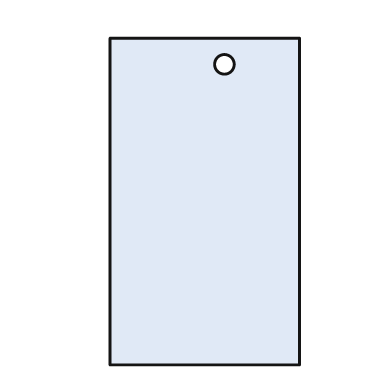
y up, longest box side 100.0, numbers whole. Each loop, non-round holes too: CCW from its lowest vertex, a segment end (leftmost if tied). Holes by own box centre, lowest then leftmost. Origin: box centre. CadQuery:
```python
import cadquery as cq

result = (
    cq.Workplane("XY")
    .moveTo(-29.0, -50.0)
    .lineTo(29.0, -50.0)
    .lineTo(29.0, 50.0)
    .lineTo(-29.0, 50.0)
    .close()
    .moveTo(6.0, 42.0)
    .circle(3.0)
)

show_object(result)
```